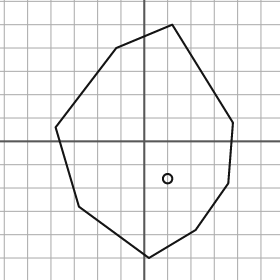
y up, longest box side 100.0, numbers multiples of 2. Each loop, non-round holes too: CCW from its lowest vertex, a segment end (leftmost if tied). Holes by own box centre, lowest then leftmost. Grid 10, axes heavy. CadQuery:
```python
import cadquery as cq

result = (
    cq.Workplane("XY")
    .moveTo(2.0, -50.0)
    .lineTo(22.0, -38.0)
    .lineTo(36.0, -18.0)
    .lineTo(38.0, 8.0)
    .lineTo(12.0, 50.0)
    .lineTo(-12.0, 40.0)
    .lineTo(-38.0, 6.0)
    .lineTo(-28.0, -28.0)
    .close()
    .moveTo(10.0, -16.0)
    .circle(2.0)
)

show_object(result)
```